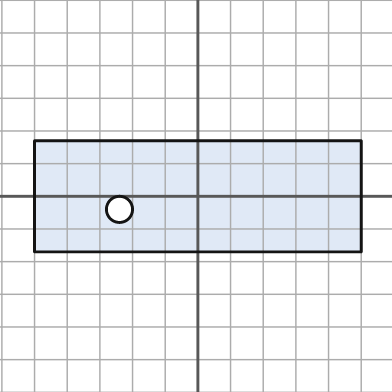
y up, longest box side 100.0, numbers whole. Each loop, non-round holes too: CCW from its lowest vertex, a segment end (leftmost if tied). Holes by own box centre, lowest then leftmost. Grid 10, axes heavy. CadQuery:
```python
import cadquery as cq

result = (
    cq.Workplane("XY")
    .moveTo(-50.0, -17.0)
    .lineTo(50.0, -17.0)
    .lineTo(50.0, 17.0)
    .lineTo(-50.0, 17.0)
    .close()
    .moveTo(-24.0, -4.0)
    .circle(4.0)
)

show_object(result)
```